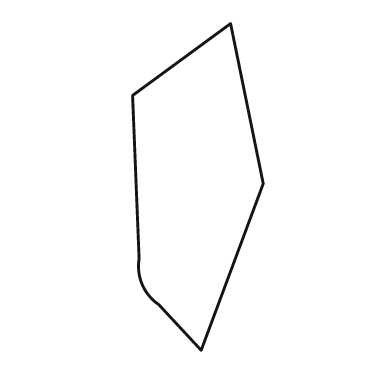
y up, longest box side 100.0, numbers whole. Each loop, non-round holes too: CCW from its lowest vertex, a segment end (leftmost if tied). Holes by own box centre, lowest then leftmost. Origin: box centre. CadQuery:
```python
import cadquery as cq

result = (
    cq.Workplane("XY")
    .moveTo(1.0, -50.0)
    .lineTo(20.0, 1.0)
    .lineTo(10.0, 50.0)
    .lineTo(-20.0, 28.0)
    .lineTo(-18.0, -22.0)
    .threePointArc((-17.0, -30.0), (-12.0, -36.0))
    .close()
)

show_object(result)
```